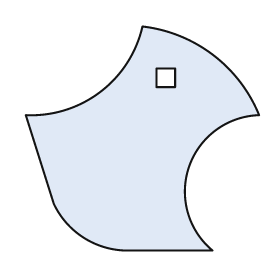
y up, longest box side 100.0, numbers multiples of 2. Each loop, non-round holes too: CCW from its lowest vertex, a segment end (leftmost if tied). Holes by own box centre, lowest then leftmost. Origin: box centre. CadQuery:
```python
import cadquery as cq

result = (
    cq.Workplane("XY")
    .moveTo(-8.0, -48.0)
    .lineTo(30.0, -48.0)
    .threePointArc((20.0, -12.0), (50.0, 10.0))
    .threePointArc((30.0, 36.0), (0.0, 48.0))
    .threePointArc((-18.0, 20.0), (-50.0, 10.0))
    .lineTo(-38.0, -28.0)
    .threePointArc((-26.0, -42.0), (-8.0, -48.0))
    .close()
    .moveTo(6.0, 22.0)
    .lineTo(14.0, 22.0)
    .lineTo(14.0, 30.0)
    .lineTo(6.0, 30.0)
    .close()
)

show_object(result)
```